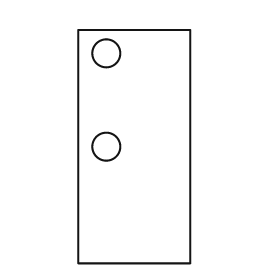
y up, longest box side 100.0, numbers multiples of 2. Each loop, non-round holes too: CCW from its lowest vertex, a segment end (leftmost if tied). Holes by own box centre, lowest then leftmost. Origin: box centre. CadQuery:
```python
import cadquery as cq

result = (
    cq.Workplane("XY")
    .moveTo(-24.0, -50.0)
    .lineTo(24.0, -50.0)
    .lineTo(24.0, 50.0)
    .lineTo(-24.0, 50.0)
    .close()
    .moveTo(-12.0, 0.0)
    .circle(6.0)
    .moveTo(-12.0, 40.0)
    .circle(6.0)
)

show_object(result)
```